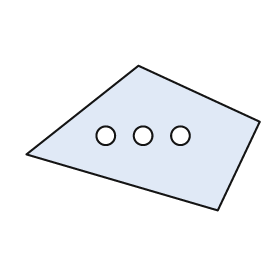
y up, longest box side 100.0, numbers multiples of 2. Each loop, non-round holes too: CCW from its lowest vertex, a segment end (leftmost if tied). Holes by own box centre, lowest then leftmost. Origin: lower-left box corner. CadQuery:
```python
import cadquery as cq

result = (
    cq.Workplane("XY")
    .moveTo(82.0, 0.0)
    .lineTo(100.0, 38.0)
    .lineTo(48.0, 62.0)
    .lineTo(0.0, 24.0)
    .close()
    .moveTo(34.0, 32.0)
    .circle(4.0)
    .moveTo(50.0, 32.0)
    .circle(4.0)
    .moveTo(66.0, 32.0)
    .circle(4.0)
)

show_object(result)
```